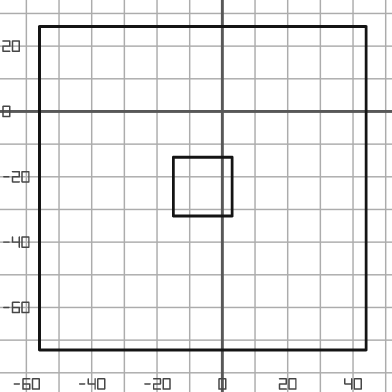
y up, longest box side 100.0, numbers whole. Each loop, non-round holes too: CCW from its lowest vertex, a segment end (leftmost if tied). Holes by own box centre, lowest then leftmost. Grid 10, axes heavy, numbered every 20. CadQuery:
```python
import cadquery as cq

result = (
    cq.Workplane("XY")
    .moveTo(-56.0, -73.0)
    .lineTo(44.0, -73.0)
    .lineTo(44.0, 26.0)
    .lineTo(-56.0, 26.0)
    .close()
    .moveTo(-15.0, -32.0)
    .lineTo(3.0, -32.0)
    .lineTo(3.0, -14.0)
    .lineTo(-15.0, -14.0)
    .close()
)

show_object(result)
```